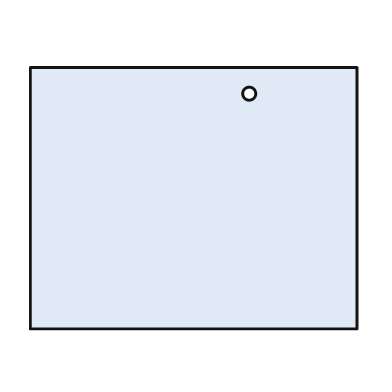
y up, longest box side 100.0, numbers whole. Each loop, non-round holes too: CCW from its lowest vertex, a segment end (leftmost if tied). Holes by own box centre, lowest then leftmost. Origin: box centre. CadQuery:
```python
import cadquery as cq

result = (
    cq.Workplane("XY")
    .moveTo(-50.0, -40.0)
    .lineTo(50.0, -40.0)
    .lineTo(50.0, 40.0)
    .lineTo(-50.0, 40.0)
    .close()
    .moveTo(17.0, 32.0)
    .circle(2.0)
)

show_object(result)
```